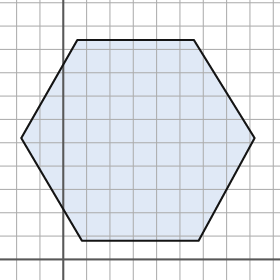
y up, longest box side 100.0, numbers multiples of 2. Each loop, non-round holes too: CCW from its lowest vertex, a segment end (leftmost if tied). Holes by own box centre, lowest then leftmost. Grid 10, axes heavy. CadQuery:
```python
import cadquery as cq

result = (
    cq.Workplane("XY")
    .moveTo(8.0, 8.0)
    .lineTo(58.0, 8.0)
    .lineTo(82.0, 52.0)
    .lineTo(56.0, 94.0)
    .lineTo(6.0, 94.0)
    .lineTo(-18.0, 52.0)
    .close()
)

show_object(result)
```